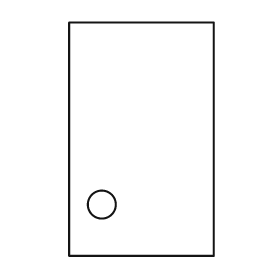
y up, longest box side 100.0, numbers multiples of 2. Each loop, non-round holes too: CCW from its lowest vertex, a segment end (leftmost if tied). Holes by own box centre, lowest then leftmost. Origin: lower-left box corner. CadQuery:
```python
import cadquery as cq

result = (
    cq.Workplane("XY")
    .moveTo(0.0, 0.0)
    .lineTo(62.0, 0.0)
    .lineTo(62.0, 100.0)
    .lineTo(0.0, 100.0)
    .close()
    .moveTo(14.0, 22.0)
    .circle(6.0)
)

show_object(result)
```